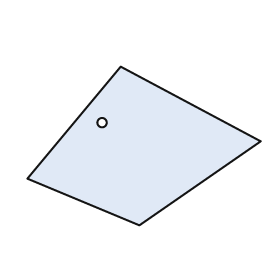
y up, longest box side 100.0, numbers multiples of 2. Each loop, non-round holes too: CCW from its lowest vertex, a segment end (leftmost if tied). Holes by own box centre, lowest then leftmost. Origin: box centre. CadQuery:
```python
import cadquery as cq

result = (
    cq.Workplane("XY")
    .moveTo(-2.0, -34.0)
    .lineTo(50.0, 2.0)
    .lineTo(-10.0, 34.0)
    .lineTo(-50.0, -14.0)
    .close()
    .moveTo(-18.0, 10.0)
    .circle(2.0)
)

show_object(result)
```